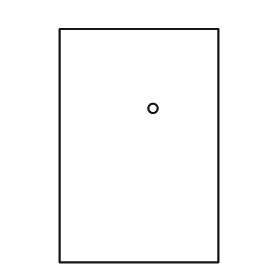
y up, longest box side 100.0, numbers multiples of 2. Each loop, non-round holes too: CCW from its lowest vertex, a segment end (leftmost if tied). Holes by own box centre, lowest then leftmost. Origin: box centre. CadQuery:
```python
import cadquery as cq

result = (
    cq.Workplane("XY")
    .moveTo(-34.0, -50.0)
    .lineTo(34.0, -50.0)
    .lineTo(34.0, 50.0)
    .lineTo(-34.0, 50.0)
    .close()
    .moveTo(6.0, 16.0)
    .circle(2.0)
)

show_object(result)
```